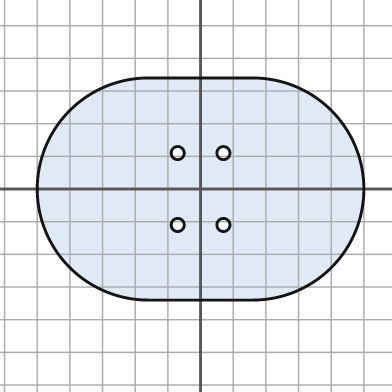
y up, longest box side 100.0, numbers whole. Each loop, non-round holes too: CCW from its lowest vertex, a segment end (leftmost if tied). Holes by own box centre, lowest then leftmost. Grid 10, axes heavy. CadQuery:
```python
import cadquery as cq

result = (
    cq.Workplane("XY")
    .moveTo(-16.0, -34.0)
    .lineTo(16.0, -34.0)
    .threePointArc((50.0, 0.0), (16.0, 34.0))
    .lineTo(-16.0, 34.0)
    .threePointArc((-50.0, 0.0), (-16.0, -34.0))
    .close()
    .moveTo(-7.0, -11.0)
    .circle(2.0)
    .moveTo(7.0, -11.0)
    .circle(2.0)
    .moveTo(-7.0, 11.0)
    .circle(2.0)
    .moveTo(7.0, 11.0)
    .circle(2.0)
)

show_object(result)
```